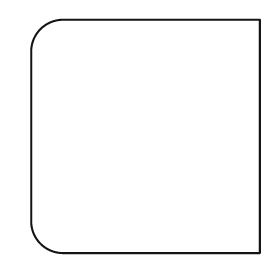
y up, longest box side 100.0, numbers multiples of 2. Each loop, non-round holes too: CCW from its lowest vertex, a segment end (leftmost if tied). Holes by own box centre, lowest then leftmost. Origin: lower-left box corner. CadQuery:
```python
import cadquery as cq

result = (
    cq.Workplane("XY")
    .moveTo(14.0, 0.0)
    .lineTo(98.0, 0.0)
    .lineTo(98.0, 100.0)
    .lineTo(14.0, 100.0)
    .threePointArc((4.0, 96.0), (0.0, 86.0))
    .lineTo(0.0, 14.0)
    .threePointArc((4.0, 4.0), (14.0, 0.0))
    .close()
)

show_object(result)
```